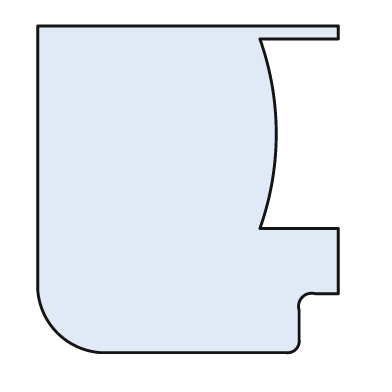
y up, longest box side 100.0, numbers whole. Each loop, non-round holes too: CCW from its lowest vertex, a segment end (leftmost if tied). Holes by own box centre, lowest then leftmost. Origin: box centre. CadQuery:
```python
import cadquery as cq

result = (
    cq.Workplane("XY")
    .moveTo(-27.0, -50.0)
    .lineTo(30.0, -50.0)
    .threePointArc((33.0, -49.0), (34.0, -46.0))
    .lineTo(34.0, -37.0)
    .threePointArc((35.0, -33.0), (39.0, -32.0))
    .lineTo(46.0, -32.0)
    .lineTo(46.0, -12.0)
    .lineTo(22.0, -12.0)
    .threePointArc((27.0, 17.0), (22.0, 46.0))
    .lineTo(46.0, 46.0)
    .lineTo(46.0, 50.0)
    .lineTo(-46.0, 50.0)
    .lineTo(-46.0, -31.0)
    .threePointArc((-40.0, -44.0), (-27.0, -50.0))
    .close()
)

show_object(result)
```